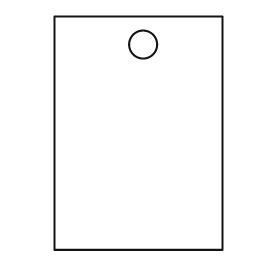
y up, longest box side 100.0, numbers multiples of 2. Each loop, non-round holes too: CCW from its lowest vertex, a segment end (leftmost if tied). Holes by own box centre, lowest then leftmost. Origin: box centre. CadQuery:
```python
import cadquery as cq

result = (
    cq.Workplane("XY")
    .moveTo(-36.0, -50.0)
    .lineTo(36.0, -50.0)
    .lineTo(36.0, 50.0)
    .lineTo(-36.0, 50.0)
    .close()
    .moveTo(2.0, 38.0)
    .circle(6.0)
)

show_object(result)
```